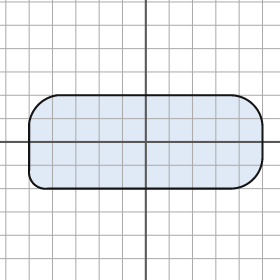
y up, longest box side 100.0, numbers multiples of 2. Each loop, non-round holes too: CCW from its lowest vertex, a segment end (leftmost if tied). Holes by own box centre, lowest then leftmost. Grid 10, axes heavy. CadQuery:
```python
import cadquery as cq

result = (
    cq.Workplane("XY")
    .moveTo(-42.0, -20.0)
    .lineTo(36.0, -20.0)
    .threePointArc((46.0, -16.0), (50.0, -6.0))
    .lineTo(50.0, 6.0)
    .threePointArc((46.0, 16.0), (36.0, 20.0))
    .lineTo(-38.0, 20.0)
    .threePointArc((-46.0, 16.0), (-50.0, 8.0))
    .lineTo(-50.0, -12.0)
    .threePointArc((-48.0, -18.0), (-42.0, -20.0))
    .close()
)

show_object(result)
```